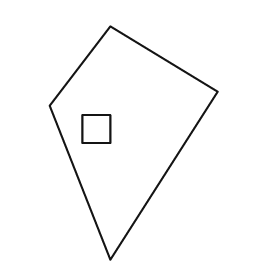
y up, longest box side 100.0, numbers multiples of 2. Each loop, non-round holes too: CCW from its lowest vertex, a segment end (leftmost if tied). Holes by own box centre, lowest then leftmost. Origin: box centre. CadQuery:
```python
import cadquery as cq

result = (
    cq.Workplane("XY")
    .moveTo(-10.0, -50.0)
    .lineTo(36.0, 22.0)
    .lineTo(-10.0, 50.0)
    .lineTo(-36.0, 16.0)
    .close()
    .moveTo(-22.0, 0.0)
    .lineTo(-10.0, 0.0)
    .lineTo(-10.0, 12.0)
    .lineTo(-22.0, 12.0)
    .close()
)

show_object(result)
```